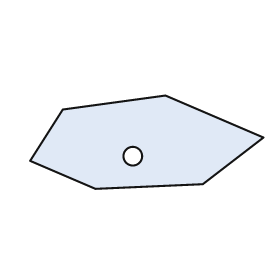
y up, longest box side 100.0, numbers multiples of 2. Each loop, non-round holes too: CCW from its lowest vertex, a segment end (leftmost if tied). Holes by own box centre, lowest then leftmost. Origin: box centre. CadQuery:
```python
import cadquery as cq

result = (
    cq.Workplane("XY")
    .moveTo(-22.0, -20.0)
    .lineTo(24.0, -18.0)
    .lineTo(50.0, 2.0)
    .lineTo(8.0, 20.0)
    .lineTo(-36.0, 14.0)
    .lineTo(-50.0, -8.0)
    .close()
    .moveTo(-6.0, -6.0)
    .circle(4.0)
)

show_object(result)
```